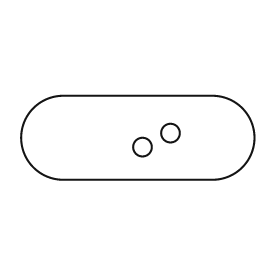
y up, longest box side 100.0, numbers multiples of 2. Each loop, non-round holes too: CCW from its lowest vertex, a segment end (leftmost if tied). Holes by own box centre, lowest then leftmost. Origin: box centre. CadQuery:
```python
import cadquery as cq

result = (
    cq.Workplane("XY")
    .moveTo(-32.0, -18.0)
    .lineTo(32.0, -18.0)
    .threePointArc((50.0, 0.0), (32.0, 18.0))
    .lineTo(-32.0, 18.0)
    .threePointArc((-50.0, 0.0), (-32.0, -18.0))
    .close()
    .moveTo(2.0, -4.0)
    .circle(4.0)
    .moveTo(14.0, 2.0)
    .circle(4.0)
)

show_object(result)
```